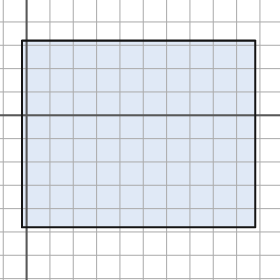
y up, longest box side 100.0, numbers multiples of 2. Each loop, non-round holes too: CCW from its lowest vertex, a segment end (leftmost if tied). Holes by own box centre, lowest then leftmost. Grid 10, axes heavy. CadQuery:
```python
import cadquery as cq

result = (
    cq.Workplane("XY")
    .moveTo(-2.0, -48.0)
    .lineTo(98.0, -48.0)
    .lineTo(98.0, 32.0)
    .lineTo(-2.0, 32.0)
    .close()
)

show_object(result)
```